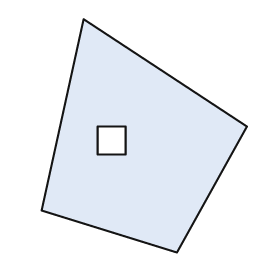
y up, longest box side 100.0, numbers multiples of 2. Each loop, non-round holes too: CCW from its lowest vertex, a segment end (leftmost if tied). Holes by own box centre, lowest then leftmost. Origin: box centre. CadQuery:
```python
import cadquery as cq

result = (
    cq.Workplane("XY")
    .moveTo(14.0, -50.0)
    .lineTo(44.0, 4.0)
    .lineTo(-26.0, 50.0)
    .lineTo(-44.0, -32.0)
    .close()
    .moveTo(-20.0, -8.0)
    .lineTo(-8.0, -8.0)
    .lineTo(-8.0, 4.0)
    .lineTo(-20.0, 4.0)
    .close()
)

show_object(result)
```